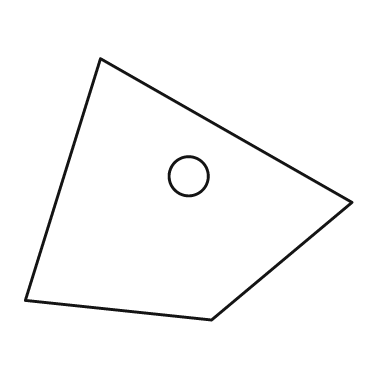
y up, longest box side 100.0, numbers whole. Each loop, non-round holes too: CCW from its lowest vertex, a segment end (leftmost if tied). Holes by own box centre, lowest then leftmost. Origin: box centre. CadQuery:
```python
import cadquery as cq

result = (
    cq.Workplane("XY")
    .moveTo(7.0, -40.0)
    .lineTo(50.0, -4.0)
    .lineTo(-27.0, 40.0)
    .lineTo(-50.0, -34.0)
    .close()
    .moveTo(0.0, 4.0)
    .circle(6.0)
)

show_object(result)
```